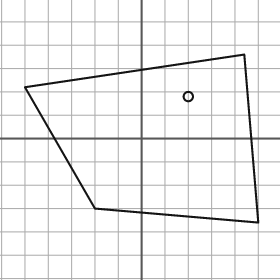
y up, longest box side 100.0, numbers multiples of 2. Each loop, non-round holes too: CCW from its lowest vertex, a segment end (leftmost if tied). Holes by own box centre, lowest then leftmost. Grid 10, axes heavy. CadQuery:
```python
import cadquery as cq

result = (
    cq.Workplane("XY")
    .moveTo(50.0, -36.0)
    .lineTo(44.0, 36.0)
    .lineTo(-50.0, 22.0)
    .lineTo(-20.0, -30.0)
    .close()
    .moveTo(20.0, 18.0)
    .circle(2.0)
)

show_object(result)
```